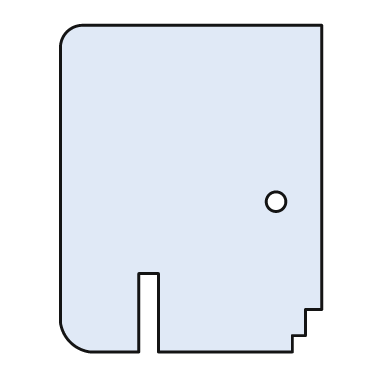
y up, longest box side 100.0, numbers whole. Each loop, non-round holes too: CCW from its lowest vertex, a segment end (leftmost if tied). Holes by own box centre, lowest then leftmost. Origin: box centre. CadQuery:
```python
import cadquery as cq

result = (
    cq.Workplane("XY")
    .moveTo(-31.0, -50.0)
    .lineTo(-16.0, -50.0)
    .lineTo(-16.0, -26.0)
    .lineTo(-10.0, -26.0)
    .lineTo(-10.0, -50.0)
    .lineTo(31.0, -50.0)
    .lineTo(31.0, -45.0)
    .lineTo(35.0, -45.0)
    .lineTo(35.0, -37.0)
    .lineTo(40.0, -37.0)
    .lineTo(40.0, 50.0)
    .lineTo(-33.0, 50.0)
    .threePointArc((-38.0, 48.0), (-40.0, 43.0))
    .lineTo(-40.0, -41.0)
    .threePointArc((-37.0, -47.0), (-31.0, -50.0))
    .close()
    .moveTo(26.0, -4.0)
    .circle(3.0)
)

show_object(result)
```